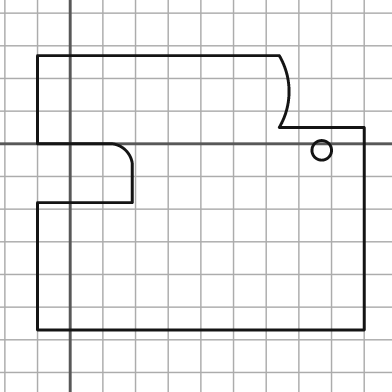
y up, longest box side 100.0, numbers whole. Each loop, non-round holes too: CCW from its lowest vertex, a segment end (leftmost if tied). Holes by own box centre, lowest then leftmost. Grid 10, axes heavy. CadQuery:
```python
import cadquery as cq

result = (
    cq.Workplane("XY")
    .moveTo(-10.0, -57.0)
    .lineTo(90.0, -57.0)
    .lineTo(90.0, 5.0)
    .lineTo(64.0, 5.0)
    .threePointArc((67.0, 16.0), (64.0, 27.0))
    .lineTo(-10.0, 27.0)
    .lineTo(-10.0, 0.0)
    .lineTo(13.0, 0.0)
    .threePointArc((17.0, -2.0), (19.0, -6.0))
    .lineTo(19.0, -18.0)
    .lineTo(-10.0, -18.0)
    .close()
    .moveTo(77.0, -2.0)
    .circle(3.0)
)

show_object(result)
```